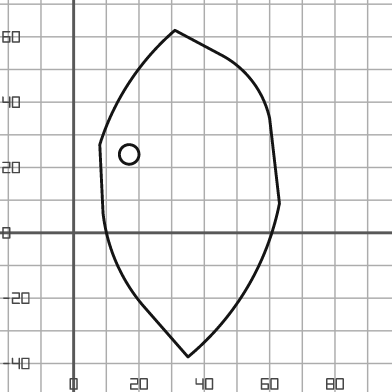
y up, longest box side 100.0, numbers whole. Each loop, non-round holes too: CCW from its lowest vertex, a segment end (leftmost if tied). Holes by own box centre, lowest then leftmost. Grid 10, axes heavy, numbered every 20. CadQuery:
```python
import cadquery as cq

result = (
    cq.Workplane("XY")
    .moveTo(35.0, -38.0)
    .threePointArc((53.0, -17.0), (63.0, 9.0))
    .lineTo(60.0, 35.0)
    .threePointArc((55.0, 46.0), (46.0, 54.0))
    .lineTo(31.0, 62.0)
    .threePointArc((17.0, 46.0), (8.0, 27.0))
    .lineTo(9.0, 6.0)
    .threePointArc((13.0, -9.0), (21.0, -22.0))
    .close()
    .moveTo(17.0, 24.0)
    .circle(3.0)
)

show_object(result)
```